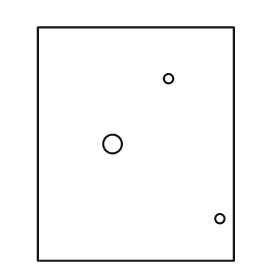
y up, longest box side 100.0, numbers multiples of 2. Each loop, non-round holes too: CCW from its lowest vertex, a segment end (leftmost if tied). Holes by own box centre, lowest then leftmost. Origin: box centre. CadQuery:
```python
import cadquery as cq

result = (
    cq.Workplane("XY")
    .moveTo(-42.0, -50.0)
    .lineTo(42.0, -50.0)
    .lineTo(42.0, 50.0)
    .lineTo(-42.0, 50.0)
    .close()
    .moveTo(36.0, -32.0)
    .circle(2.0)
    .moveTo(-10.0, 0.0)
    .circle(4.0)
    .moveTo(14.0, 28.0)
    .circle(2.0)
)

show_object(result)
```